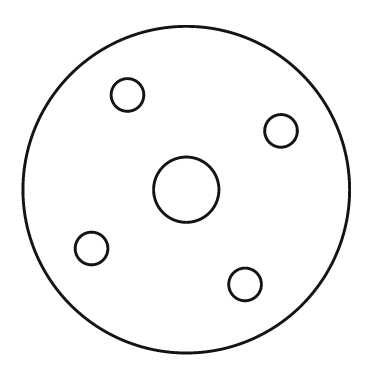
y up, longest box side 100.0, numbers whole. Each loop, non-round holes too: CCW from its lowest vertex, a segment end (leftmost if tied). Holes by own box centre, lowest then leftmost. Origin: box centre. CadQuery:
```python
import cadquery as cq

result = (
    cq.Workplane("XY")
    .moveTo(0.0, 0.0)
    .circle(50.0)
    .moveTo(18.0, -29.0)
    .circle(5.0)
    .moveTo(-29.0, -18.0)
    .circle(5.0)
    .moveTo(0.0, 0.0)
    .circle(10.0)
    .moveTo(29.0, 18.0)
    .circle(5.0)
    .moveTo(-18.0, 29.0)
    .circle(5.0)
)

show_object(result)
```